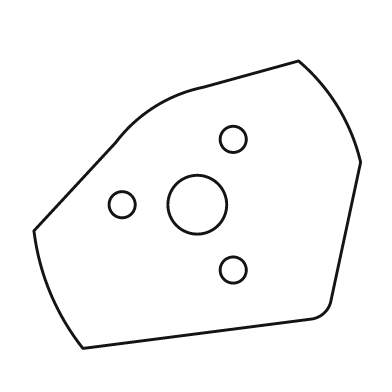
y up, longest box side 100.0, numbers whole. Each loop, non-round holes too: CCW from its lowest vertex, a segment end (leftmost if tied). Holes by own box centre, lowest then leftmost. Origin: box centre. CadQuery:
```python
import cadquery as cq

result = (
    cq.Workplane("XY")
    .moveTo(-35.0, -44.0)
    .lineTo(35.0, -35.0)
    .threePointArc((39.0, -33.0), (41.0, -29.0))
    .lineTo(50.0, 13.0)
    .threePointArc((43.0, 30.0), (31.0, 44.0))
    .lineTo(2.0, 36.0)
    .threePointArc((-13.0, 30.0), (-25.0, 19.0))
    .lineTo(-50.0, -8.0)
    .threePointArc((-45.0, -27.0), (-35.0, -44.0))
    .close()
    .moveTo(11.0, -20.0)
    .circle(4.0)
    .moveTo(-23.0, 0.0)
    .circle(4.0)
    .moveTo(0.0, 0.0)
    .circle(9.0)
    .moveTo(11.0, 20.0)
    .circle(4.0)
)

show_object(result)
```